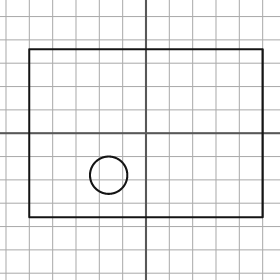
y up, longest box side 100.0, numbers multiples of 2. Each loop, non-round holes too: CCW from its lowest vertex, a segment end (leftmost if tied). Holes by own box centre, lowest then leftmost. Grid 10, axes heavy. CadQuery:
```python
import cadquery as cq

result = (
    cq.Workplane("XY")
    .moveTo(-50.0, -36.0)
    .lineTo(50.0, -36.0)
    .lineTo(50.0, 36.0)
    .lineTo(-50.0, 36.0)
    .close()
    .moveTo(-16.0, -18.0)
    .circle(8.0)
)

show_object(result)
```